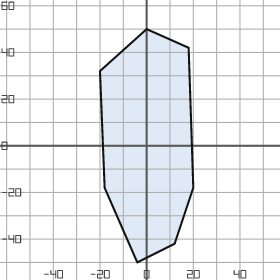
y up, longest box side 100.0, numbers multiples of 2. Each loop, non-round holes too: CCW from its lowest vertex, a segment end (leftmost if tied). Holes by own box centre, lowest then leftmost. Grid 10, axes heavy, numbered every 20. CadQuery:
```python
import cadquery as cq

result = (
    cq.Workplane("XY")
    .moveTo(-4.0, -50.0)
    .lineTo(12.0, -42.0)
    .lineTo(20.0, -18.0)
    .lineTo(18.0, 42.0)
    .lineTo(0.0, 50.0)
    .lineTo(-20.0, 32.0)
    .lineTo(-18.0, -18.0)
    .close()
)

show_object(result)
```